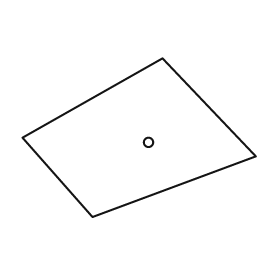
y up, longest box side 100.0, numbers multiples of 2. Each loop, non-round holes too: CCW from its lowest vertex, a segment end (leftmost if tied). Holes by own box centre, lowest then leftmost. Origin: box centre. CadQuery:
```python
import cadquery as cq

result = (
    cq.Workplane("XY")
    .moveTo(-20.0, -34.0)
    .lineTo(50.0, -8.0)
    .lineTo(10.0, 34.0)
    .lineTo(-50.0, 0.0)
    .close()
    .moveTo(4.0, -2.0)
    .circle(2.0)
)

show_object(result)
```